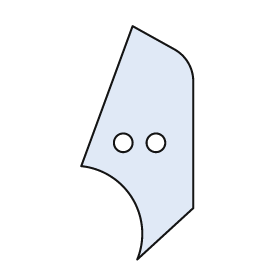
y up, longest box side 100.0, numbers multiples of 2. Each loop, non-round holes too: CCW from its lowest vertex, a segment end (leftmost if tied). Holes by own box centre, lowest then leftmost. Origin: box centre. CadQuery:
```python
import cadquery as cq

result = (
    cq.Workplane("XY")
    .moveTo(0.0, -50.0)
    .lineTo(24.0, -28.0)
    .lineTo(24.0, 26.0)
    .threePointArc((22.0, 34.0), (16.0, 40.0))
    .lineTo(-2.0, 50.0)
    .lineTo(-24.0, -10.0)
    .threePointArc((-2.0, -24.0), (0.0, -50.0))
    .close()
    .moveTo(-6.0, 0.0)
    .circle(4.0)
    .moveTo(8.0, 0.0)
    .circle(4.0)
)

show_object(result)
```